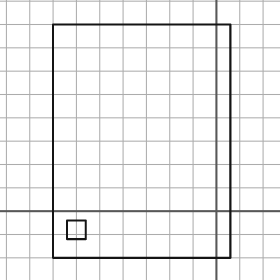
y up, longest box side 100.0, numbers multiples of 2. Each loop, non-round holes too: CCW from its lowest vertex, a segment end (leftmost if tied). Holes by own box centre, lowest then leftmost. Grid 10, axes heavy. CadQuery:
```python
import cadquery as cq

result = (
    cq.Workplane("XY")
    .moveTo(-70.0, -20.0)
    .lineTo(6.0, -20.0)
    .lineTo(6.0, 80.0)
    .lineTo(-70.0, 80.0)
    .close()
    .moveTo(-64.0, -12.0)
    .lineTo(-56.0, -12.0)
    .lineTo(-56.0, -4.0)
    .lineTo(-64.0, -4.0)
    .close()
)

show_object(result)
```